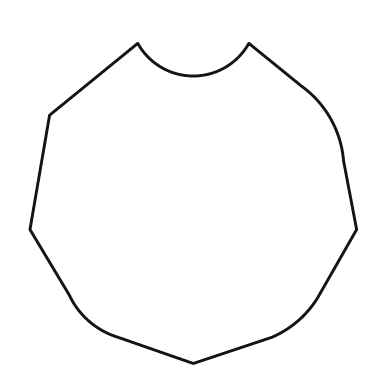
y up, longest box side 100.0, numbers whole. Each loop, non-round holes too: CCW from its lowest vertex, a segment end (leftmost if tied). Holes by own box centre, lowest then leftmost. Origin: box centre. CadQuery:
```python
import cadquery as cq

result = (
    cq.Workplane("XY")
    .moveTo(0.0, -49.0)
    .lineTo(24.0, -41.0)
    .threePointArc((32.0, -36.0), (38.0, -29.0))
    .lineTo(50.0, -8.0)
    .lineTo(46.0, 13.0)
    .threePointArc((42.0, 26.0), (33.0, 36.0))
    .lineTo(17.0, 49.0)
    .threePointArc((0.0, 39.0), (-17.0, 49.0))
    .lineTo(-44.0, 27.0)
    .lineTo(-50.0, -8.0)
    .lineTo(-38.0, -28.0)
    .threePointArc((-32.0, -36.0), (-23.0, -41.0))
    .close()
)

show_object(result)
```